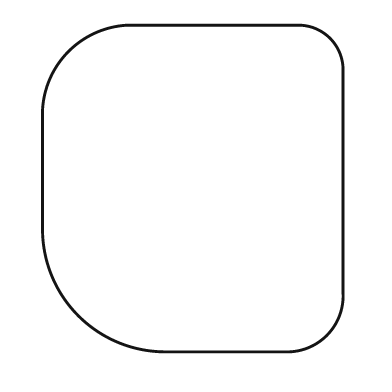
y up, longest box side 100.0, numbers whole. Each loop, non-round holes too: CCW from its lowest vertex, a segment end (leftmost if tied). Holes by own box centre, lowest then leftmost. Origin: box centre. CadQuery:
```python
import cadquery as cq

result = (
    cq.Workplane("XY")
    .moveTo(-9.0, -50.0)
    .lineTo(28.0, -50.0)
    .threePointArc((41.0, -45.0), (46.0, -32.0))
    .lineTo(46.0, 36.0)
    .threePointArc((42.0, 46.0), (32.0, 50.0))
    .lineTo(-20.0, 50.0)
    .threePointArc((-38.0, 42.0), (-46.0, 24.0))
    .lineTo(-46.0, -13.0)
    .threePointArc((-35.0, -39.0), (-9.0, -50.0))
    .close()
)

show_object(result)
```